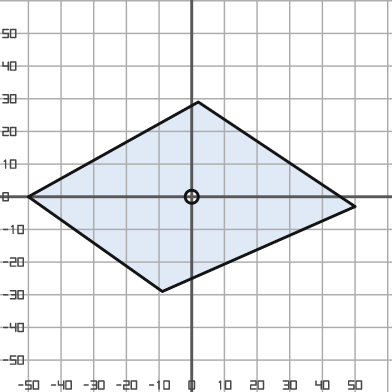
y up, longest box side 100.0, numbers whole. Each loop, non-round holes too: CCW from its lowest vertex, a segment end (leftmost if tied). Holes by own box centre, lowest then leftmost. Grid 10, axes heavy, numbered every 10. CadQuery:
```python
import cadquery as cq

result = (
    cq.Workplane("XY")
    .moveTo(-9.0, -29.0)
    .lineTo(50.0, -3.0)
    .lineTo(2.0, 29.0)
    .lineTo(-50.0, 0.0)
    .close()
    .moveTo(0.0, 0.0)
    .circle(2.0)
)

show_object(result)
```